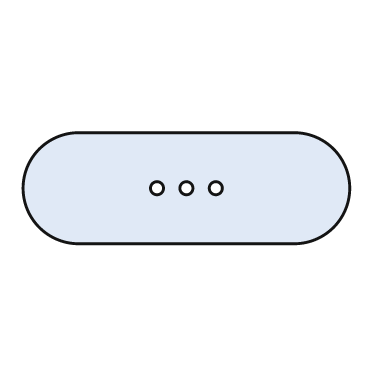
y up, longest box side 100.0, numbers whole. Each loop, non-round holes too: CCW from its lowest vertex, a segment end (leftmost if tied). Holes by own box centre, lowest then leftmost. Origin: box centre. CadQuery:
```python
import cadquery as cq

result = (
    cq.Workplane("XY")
    .moveTo(-33.0, -17.0)
    .lineTo(33.0, -17.0)
    .threePointArc((50.0, 0.0), (33.0, 17.0))
    .lineTo(-33.0, 17.0)
    .threePointArc((-50.0, 0.0), (-33.0, -17.0))
    .close()
    .moveTo(-9.0, 0.0)
    .circle(2.0)
    .moveTo(0.0, 0.0)
    .circle(2.0)
    .moveTo(9.0, 0.0)
    .circle(2.0)
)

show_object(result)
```